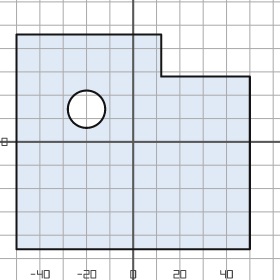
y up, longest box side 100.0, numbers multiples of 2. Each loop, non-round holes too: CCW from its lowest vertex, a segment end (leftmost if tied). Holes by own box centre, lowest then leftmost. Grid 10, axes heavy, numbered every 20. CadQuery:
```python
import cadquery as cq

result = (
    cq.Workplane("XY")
    .moveTo(-50.0, -46.0)
    .lineTo(50.0, -46.0)
    .lineTo(50.0, 28.0)
    .lineTo(12.0, 28.0)
    .lineTo(12.0, 46.0)
    .lineTo(-50.0, 46.0)
    .close()
    .moveTo(-20.0, 14.0)
    .circle(8.0)
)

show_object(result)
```